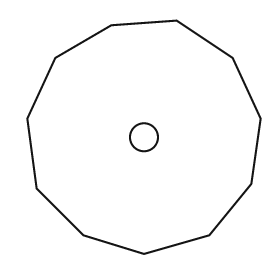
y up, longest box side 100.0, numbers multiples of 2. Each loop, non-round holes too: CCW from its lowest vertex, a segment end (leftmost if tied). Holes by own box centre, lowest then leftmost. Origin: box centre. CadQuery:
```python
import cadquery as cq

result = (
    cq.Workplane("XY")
    .moveTo(0.0, -50.0)
    .lineTo(28.0, -42.0)
    .lineTo(46.0, -20.0)
    .lineTo(50.0, 8.0)
    .lineTo(38.0, 34.0)
    .lineTo(14.0, 50.0)
    .lineTo(-14.0, 48.0)
    .lineTo(-38.0, 34.0)
    .lineTo(-50.0, 8.0)
    .lineTo(-46.0, -22.0)
    .lineTo(-26.0, -42.0)
    .close()
    .moveTo(0.0, 0.0)
    .circle(6.0)
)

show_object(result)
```